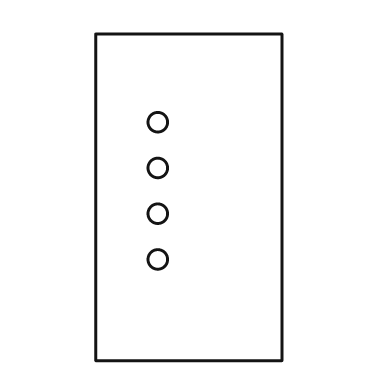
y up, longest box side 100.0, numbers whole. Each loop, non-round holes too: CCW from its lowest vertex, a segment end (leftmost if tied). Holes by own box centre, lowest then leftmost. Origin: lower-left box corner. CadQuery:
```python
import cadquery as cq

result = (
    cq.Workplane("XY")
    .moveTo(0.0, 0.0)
    .lineTo(57.0, 0.0)
    .lineTo(57.0, 100.0)
    .lineTo(0.0, 100.0)
    .close()
    .moveTo(19.0, 31.0)
    .circle(3.0)
    .moveTo(19.0, 45.0)
    .circle(3.0)
    .moveTo(19.0, 59.0)
    .circle(3.0)
    .moveTo(19.0, 73.0)
    .circle(3.0)
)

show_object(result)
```